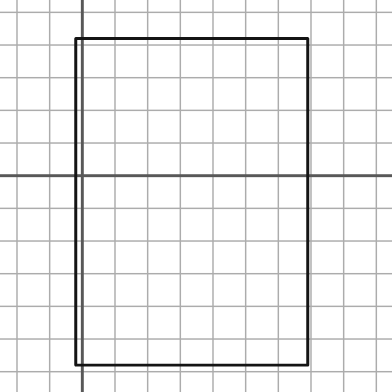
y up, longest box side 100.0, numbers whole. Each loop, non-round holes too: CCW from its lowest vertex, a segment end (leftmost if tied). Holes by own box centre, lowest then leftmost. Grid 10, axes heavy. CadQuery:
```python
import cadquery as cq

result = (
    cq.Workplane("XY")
    .moveTo(-2.0, -58.0)
    .lineTo(69.0, -58.0)
    .lineTo(69.0, 42.0)
    .lineTo(-2.0, 42.0)
    .close()
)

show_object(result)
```